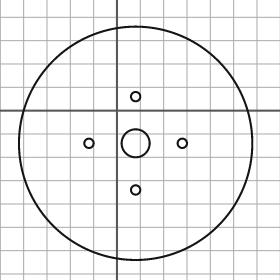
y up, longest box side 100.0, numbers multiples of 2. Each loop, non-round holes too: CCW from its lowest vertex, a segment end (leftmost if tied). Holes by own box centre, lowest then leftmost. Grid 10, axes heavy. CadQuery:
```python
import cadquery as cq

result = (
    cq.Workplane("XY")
    .moveTo(8.0, -14.0)
    .circle(50.0)
    .moveTo(8.0, -34.0)
    .circle(2.0)
    .moveTo(-12.0, -14.0)
    .circle(2.0)
    .moveTo(8.0, -14.0)
    .circle(6.0)
    .moveTo(28.0, -14.0)
    .circle(2.0)
    .moveTo(8.0, 6.0)
    .circle(2.0)
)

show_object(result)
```